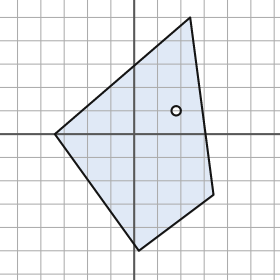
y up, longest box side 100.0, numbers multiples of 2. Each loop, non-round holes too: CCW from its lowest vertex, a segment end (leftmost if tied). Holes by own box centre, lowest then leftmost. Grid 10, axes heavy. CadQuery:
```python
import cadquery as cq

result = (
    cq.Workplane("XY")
    .moveTo(2.0, -50.0)
    .lineTo(34.0, -26.0)
    .lineTo(24.0, 50.0)
    .lineTo(-34.0, 0.0)
    .close()
    .moveTo(18.0, 10.0)
    .circle(2.0)
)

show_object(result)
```